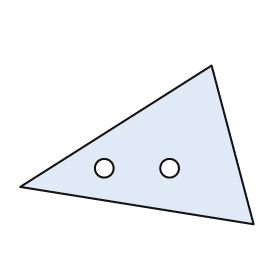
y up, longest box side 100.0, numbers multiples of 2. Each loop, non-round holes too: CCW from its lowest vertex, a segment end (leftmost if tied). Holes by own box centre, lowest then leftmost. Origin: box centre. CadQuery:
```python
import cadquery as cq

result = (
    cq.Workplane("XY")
    .moveTo(50.0, -34.0)
    .lineTo(32.0, 34.0)
    .lineTo(-50.0, -18.0)
    .close()
    .moveTo(-14.0, -10.0)
    .circle(4.0)
    .moveTo(14.0, -10.0)
    .circle(4.0)
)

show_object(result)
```